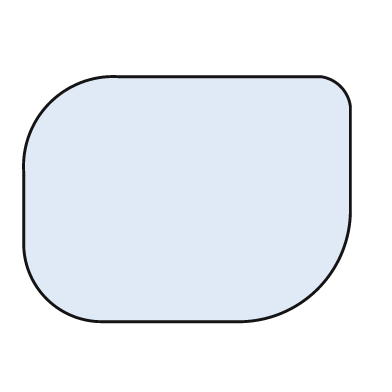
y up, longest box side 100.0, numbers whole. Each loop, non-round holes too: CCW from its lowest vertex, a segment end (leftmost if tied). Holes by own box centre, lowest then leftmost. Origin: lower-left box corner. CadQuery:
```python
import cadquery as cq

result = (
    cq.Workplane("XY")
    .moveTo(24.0, 0.0)
    .lineTo(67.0, 0.0)
    .threePointArc((90.0, 10.0), (100.0, 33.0))
    .lineTo(100.0, 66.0)
    .threePointArc((97.0, 72.0), (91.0, 75.0))
    .lineTo(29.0, 75.0)
    .threePointArc((8.0, 67.0), (0.0, 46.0))
    .lineTo(0.0, 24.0)
    .threePointArc((7.0, 7.0), (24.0, 0.0))
    .close()
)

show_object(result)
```